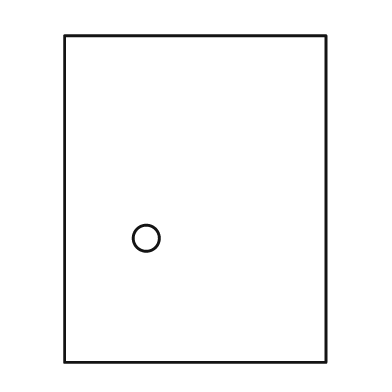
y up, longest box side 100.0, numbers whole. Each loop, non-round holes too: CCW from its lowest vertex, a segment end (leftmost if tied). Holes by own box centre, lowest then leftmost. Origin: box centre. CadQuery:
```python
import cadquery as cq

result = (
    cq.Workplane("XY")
    .moveTo(-40.0, -50.0)
    .lineTo(40.0, -50.0)
    .lineTo(40.0, 50.0)
    .lineTo(-40.0, 50.0)
    .close()
    .moveTo(-15.0, -12.0)
    .circle(4.0)
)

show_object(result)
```